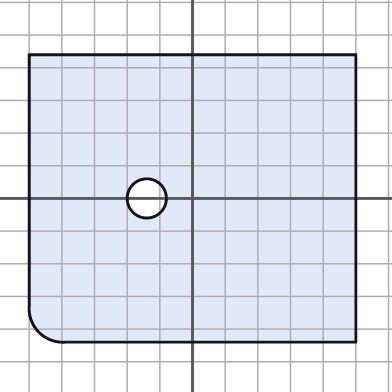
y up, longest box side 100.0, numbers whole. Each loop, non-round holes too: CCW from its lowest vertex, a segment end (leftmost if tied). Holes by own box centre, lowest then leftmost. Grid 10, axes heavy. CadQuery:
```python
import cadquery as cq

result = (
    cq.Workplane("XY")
    .moveTo(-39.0, -44.0)
    .lineTo(50.0, -44.0)
    .lineTo(50.0, 44.0)
    .lineTo(-50.0, 44.0)
    .lineTo(-50.0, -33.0)
    .threePointArc((-47.0, -41.0), (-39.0, -44.0))
    .close()
    .moveTo(-14.0, 0.0)
    .circle(6.0)
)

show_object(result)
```